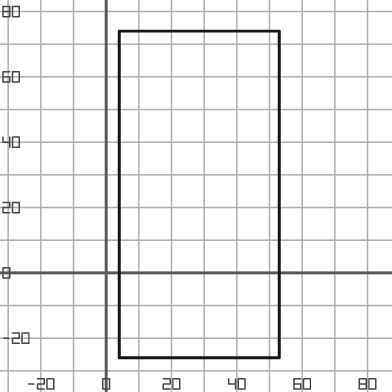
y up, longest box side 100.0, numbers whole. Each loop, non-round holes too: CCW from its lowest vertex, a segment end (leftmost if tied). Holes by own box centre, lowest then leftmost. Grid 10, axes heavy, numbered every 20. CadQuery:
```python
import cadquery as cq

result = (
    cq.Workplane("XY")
    .moveTo(4.0, -26.0)
    .lineTo(53.0, -26.0)
    .lineTo(53.0, 74.0)
    .lineTo(4.0, 74.0)
    .close()
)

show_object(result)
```